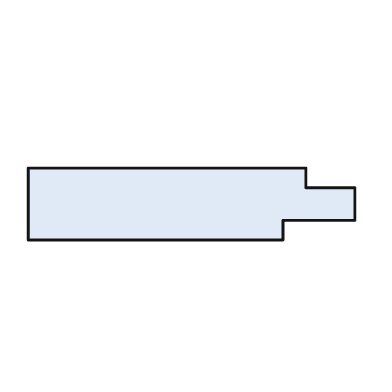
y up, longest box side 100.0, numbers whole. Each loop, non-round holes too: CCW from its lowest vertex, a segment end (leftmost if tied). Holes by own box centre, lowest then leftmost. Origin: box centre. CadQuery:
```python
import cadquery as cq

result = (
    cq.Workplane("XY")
    .moveTo(-50.0, -11.0)
    .lineTo(28.0, -11.0)
    .lineTo(28.0, -5.0)
    .lineTo(50.0, -5.0)
    .lineTo(50.0, 5.0)
    .lineTo(35.0, 5.0)
    .lineTo(35.0, 11.0)
    .lineTo(-50.0, 11.0)
    .close()
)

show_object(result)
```